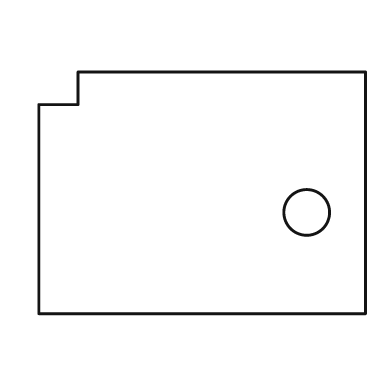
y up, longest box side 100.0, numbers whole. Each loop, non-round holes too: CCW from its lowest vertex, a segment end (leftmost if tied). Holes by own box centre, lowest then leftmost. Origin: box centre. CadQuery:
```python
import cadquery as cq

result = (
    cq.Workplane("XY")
    .moveTo(-50.0, -37.0)
    .lineTo(50.0, -37.0)
    .lineTo(50.0, 37.0)
    .lineTo(-38.0, 37.0)
    .lineTo(-38.0, 27.0)
    .lineTo(-50.0, 27.0)
    .close()
    .moveTo(32.0, -6.0)
    .circle(7.0)
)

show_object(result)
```